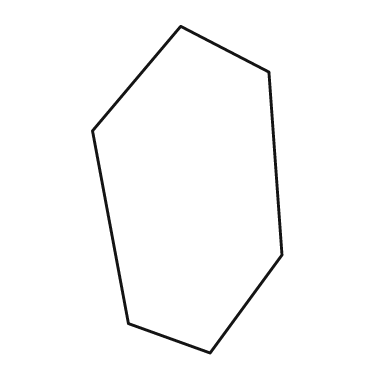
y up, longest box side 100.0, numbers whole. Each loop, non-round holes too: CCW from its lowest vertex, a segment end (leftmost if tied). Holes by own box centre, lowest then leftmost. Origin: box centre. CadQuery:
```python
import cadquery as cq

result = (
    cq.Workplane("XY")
    .moveTo(7.0, -50.0)
    .lineTo(29.0, -20.0)
    .lineTo(25.0, 36.0)
    .lineTo(-2.0, 50.0)
    .lineTo(-29.0, 18.0)
    .lineTo(-18.0, -41.0)
    .close()
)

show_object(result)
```